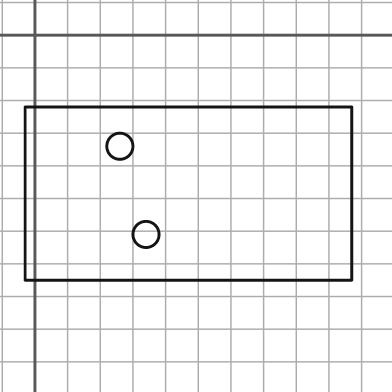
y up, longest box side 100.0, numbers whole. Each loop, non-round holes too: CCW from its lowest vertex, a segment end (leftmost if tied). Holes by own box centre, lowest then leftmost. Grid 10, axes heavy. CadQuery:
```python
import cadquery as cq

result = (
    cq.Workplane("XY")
    .moveTo(-3.0, -75.0)
    .lineTo(97.0, -75.0)
    .lineTo(97.0, -22.0)
    .lineTo(-3.0, -22.0)
    .close()
    .moveTo(34.0, -61.0)
    .circle(4.0)
    .moveTo(26.0, -34.0)
    .circle(4.0)
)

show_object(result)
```